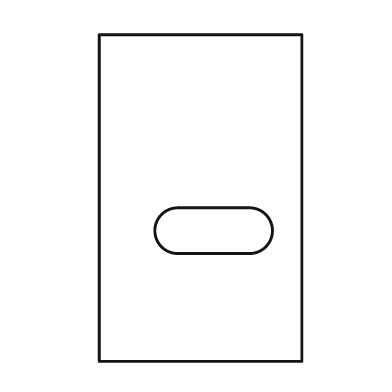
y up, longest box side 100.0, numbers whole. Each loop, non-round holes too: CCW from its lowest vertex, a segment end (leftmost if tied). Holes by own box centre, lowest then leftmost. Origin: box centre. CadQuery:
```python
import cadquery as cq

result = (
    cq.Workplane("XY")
    .moveTo(-31.0, -50.0)
    .lineTo(31.0, -50.0)
    .lineTo(31.0, 50.0)
    .lineTo(-31.0, 50.0)
    .close()
    .moveTo(-7.0, -17.0)
    .lineTo(15.0, -17.0)
    .threePointArc((22.0, -10.0), (15.0, -3.0))
    .lineTo(-7.0, -3.0)
    .threePointArc((-14.0, -10.0), (-7.0, -17.0))
    .close()
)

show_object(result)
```